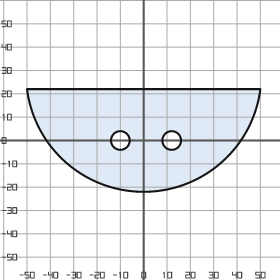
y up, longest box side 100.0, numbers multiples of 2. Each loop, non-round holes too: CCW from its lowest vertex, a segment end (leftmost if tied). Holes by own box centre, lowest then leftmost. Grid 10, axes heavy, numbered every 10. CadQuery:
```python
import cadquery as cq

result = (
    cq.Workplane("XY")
    .moveTo(-50.0, 22.0)
    .threePointArc((0.0, -22.0), (50.0, 22.0))
    .close()
    .moveTo(-10.0, 0.0)
    .circle(4.0)
    .moveTo(12.0, 0.0)
    .circle(4.0)
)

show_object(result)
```